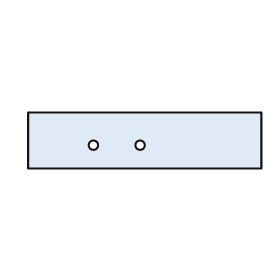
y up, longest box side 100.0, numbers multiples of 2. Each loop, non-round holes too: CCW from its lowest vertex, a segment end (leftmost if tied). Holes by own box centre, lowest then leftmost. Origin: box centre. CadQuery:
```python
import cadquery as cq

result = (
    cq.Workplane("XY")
    .moveTo(-50.0, -12.0)
    .lineTo(50.0, -12.0)
    .lineTo(50.0, 12.0)
    .lineTo(-50.0, 12.0)
    .close()
    .moveTo(-22.0, -2.0)
    .circle(2.0)
    .moveTo(-2.0, -2.0)
    .circle(2.0)
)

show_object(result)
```